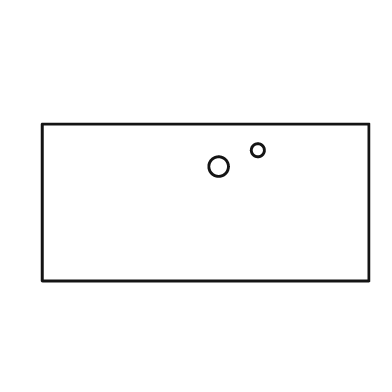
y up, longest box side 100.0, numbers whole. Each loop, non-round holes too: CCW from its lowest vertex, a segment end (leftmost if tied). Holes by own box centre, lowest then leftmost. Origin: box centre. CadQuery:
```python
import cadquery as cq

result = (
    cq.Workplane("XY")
    .moveTo(-50.0, -24.0)
    .lineTo(50.0, -24.0)
    .lineTo(50.0, 24.0)
    .lineTo(-50.0, 24.0)
    .close()
    .moveTo(4.0, 11.0)
    .circle(3.0)
    .moveTo(16.0, 16.0)
    .circle(2.0)
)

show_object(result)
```